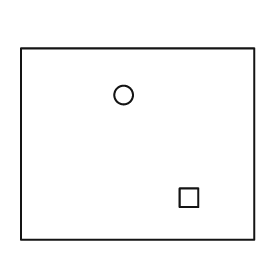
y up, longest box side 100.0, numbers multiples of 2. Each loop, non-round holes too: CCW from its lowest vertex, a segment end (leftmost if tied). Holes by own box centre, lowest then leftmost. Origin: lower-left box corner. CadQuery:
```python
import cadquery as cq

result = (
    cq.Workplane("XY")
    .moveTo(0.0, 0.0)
    .lineTo(100.0, 0.0)
    .lineTo(100.0, 82.0)
    .lineTo(0.0, 82.0)
    .close()
    .moveTo(68.0, 14.0)
    .lineTo(76.0, 14.0)
    .lineTo(76.0, 22.0)
    .lineTo(68.0, 22.0)
    .close()
    .moveTo(44.0, 62.0)
    .circle(4.0)
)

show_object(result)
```